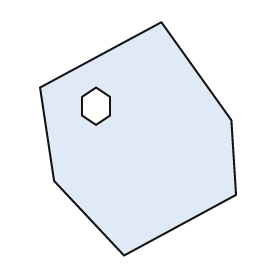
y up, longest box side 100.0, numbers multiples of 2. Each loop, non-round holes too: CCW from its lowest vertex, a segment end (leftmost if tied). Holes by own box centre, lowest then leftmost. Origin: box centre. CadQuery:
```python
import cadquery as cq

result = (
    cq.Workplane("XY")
    .moveTo(-6.0, -50.0)
    .lineTo(42.0, -24.0)
    .lineTo(40.0, 8.0)
    .lineTo(10.0, 50.0)
    .lineTo(-42.0, 22.0)
    .lineTo(-36.0, -18.0)
    .close()
    .moveTo(-18.0, 6.0)
    .lineTo(-12.0, 10.0)
    .lineTo(-12.0, 18.0)
    .lineTo(-18.0, 22.0)
    .lineTo(-24.0, 18.0)
    .lineTo(-24.0, 10.0)
    .close()
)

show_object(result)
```